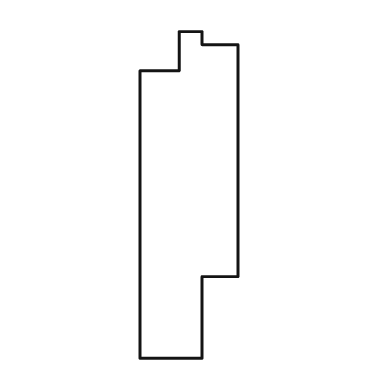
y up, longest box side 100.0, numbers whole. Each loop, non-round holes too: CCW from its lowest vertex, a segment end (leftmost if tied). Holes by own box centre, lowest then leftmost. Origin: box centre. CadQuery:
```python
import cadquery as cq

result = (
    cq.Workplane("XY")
    .moveTo(-15.0, -50.0)
    .lineTo(4.0, -50.0)
    .lineTo(4.0, -25.0)
    .lineTo(15.0, -25.0)
    .lineTo(15.0, 46.0)
    .lineTo(4.0, 46.0)
    .lineTo(4.0, 50.0)
    .lineTo(-3.0, 50.0)
    .lineTo(-3.0, 38.0)
    .lineTo(-15.0, 38.0)
    .close()
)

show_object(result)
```